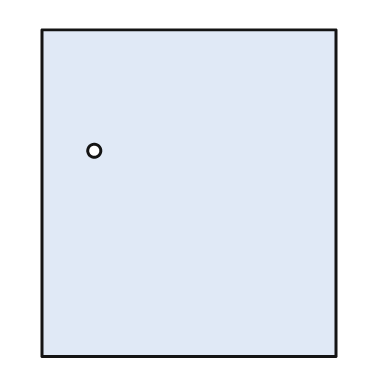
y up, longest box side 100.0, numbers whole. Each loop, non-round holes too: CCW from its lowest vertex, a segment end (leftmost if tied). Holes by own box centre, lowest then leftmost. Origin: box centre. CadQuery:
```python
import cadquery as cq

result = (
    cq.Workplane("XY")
    .moveTo(-45.0, -50.0)
    .lineTo(45.0, -50.0)
    .lineTo(45.0, 50.0)
    .lineTo(-45.0, 50.0)
    .close()
    .moveTo(-29.0, 13.0)
    .circle(2.0)
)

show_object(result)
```